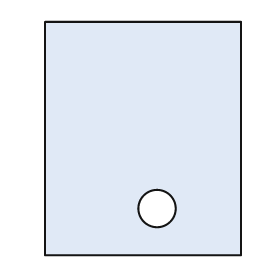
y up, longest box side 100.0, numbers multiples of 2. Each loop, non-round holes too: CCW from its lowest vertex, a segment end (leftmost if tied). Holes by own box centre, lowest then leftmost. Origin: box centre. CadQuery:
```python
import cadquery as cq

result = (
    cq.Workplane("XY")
    .moveTo(-42.0, -50.0)
    .lineTo(42.0, -50.0)
    .lineTo(42.0, 50.0)
    .lineTo(-42.0, 50.0)
    .close()
    .moveTo(6.0, -30.0)
    .circle(8.0)
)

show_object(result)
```